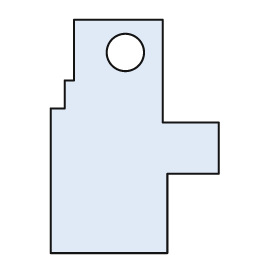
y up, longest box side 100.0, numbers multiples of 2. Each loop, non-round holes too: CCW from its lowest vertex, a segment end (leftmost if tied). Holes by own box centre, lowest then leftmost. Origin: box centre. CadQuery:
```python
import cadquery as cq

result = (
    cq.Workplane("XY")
    .moveTo(-36.0, -50.0)
    .lineTo(14.0, -50.0)
    .lineTo(14.0, -16.0)
    .lineTo(36.0, -16.0)
    .lineTo(36.0, 6.0)
    .lineTo(12.0, 6.0)
    .lineTo(12.0, 50.0)
    .lineTo(-26.0, 50.0)
    .lineTo(-26.0, 24.0)
    .lineTo(-30.0, 24.0)
    .lineTo(-30.0, 12.0)
    .lineTo(-36.0, 12.0)
    .close()
    .moveTo(-4.0, 36.0)
    .circle(8.0)
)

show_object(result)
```